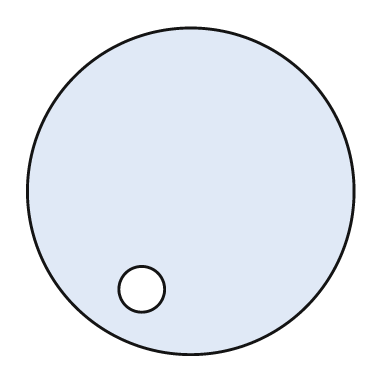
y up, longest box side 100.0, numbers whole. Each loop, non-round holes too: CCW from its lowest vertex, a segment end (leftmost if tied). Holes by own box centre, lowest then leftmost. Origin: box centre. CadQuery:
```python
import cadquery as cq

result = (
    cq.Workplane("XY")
    .moveTo(0.0, 0.0)
    .circle(50.0)
    .moveTo(-15.0, -30.0)
    .circle(7.0)
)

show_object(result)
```